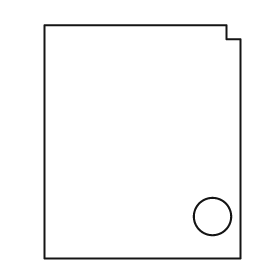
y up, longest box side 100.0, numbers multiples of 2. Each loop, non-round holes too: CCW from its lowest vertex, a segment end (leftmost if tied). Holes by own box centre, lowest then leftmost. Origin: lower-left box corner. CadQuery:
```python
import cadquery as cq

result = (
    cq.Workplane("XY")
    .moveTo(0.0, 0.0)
    .lineTo(84.0, 0.0)
    .lineTo(84.0, 94.0)
    .lineTo(78.0, 94.0)
    .lineTo(78.0, 100.0)
    .lineTo(0.0, 100.0)
    .close()
    .moveTo(72.0, 18.0)
    .circle(8.0)
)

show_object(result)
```